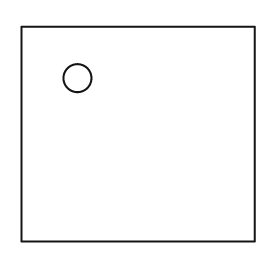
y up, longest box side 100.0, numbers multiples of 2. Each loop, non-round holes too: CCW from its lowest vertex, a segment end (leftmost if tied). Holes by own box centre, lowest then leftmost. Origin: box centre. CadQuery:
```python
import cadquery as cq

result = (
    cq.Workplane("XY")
    .moveTo(-50.0, -46.0)
    .lineTo(50.0, -46.0)
    .lineTo(50.0, 46.0)
    .lineTo(-50.0, 46.0)
    .close()
    .moveTo(-26.0, 24.0)
    .circle(6.0)
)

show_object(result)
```